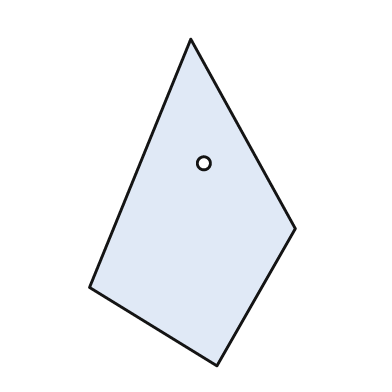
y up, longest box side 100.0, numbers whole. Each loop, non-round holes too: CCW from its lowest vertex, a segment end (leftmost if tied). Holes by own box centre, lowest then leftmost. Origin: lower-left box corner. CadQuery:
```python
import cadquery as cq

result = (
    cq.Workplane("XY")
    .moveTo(39.0, 0.0)
    .lineTo(63.0, 42.0)
    .lineTo(31.0, 100.0)
    .lineTo(0.0, 24.0)
    .close()
    .moveTo(35.0, 62.0)
    .circle(2.0)
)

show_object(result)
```